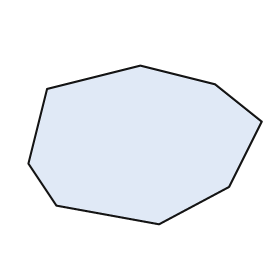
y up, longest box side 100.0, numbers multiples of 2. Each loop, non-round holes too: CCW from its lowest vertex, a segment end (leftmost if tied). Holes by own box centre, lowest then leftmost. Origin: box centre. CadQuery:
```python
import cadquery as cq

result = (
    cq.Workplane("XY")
    .moveTo(6.0, -34.0)
    .lineTo(36.0, -18.0)
    .lineTo(50.0, 10.0)
    .lineTo(30.0, 26.0)
    .lineTo(-2.0, 34.0)
    .lineTo(-42.0, 24.0)
    .lineTo(-50.0, -8.0)
    .lineTo(-38.0, -26.0)
    .close()
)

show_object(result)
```